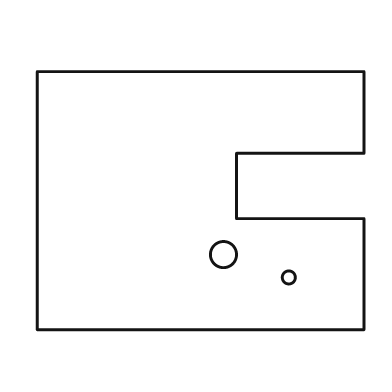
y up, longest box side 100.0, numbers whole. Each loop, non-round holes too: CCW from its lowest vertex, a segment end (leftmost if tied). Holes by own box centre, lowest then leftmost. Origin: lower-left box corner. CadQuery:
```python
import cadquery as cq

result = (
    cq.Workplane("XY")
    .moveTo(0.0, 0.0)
    .lineTo(100.0, 0.0)
    .lineTo(100.0, 34.0)
    .lineTo(61.0, 34.0)
    .lineTo(61.0, 54.0)
    .lineTo(100.0, 54.0)
    .lineTo(100.0, 79.0)
    .lineTo(0.0, 79.0)
    .close()
    .moveTo(77.0, 16.0)
    .circle(2.0)
    .moveTo(57.0, 23.0)
    .circle(4.0)
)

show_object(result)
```